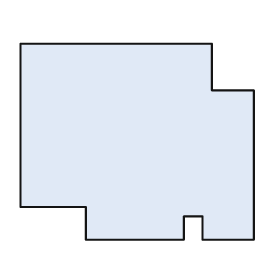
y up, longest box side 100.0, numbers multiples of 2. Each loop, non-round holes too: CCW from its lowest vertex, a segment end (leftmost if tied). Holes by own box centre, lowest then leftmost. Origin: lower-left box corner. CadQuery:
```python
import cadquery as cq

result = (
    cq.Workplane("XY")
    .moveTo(28.0, 0.0)
    .lineTo(70.0, 0.0)
    .lineTo(70.0, 10.0)
    .lineTo(78.0, 10.0)
    .lineTo(78.0, 0.0)
    .lineTo(100.0, 0.0)
    .lineTo(100.0, 64.0)
    .lineTo(82.0, 64.0)
    .lineTo(82.0, 84.0)
    .lineTo(0.0, 84.0)
    .lineTo(0.0, 14.0)
    .lineTo(28.0, 14.0)
    .close()
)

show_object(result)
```